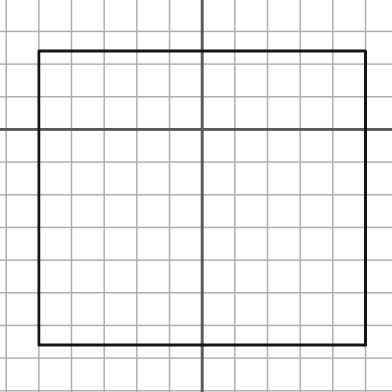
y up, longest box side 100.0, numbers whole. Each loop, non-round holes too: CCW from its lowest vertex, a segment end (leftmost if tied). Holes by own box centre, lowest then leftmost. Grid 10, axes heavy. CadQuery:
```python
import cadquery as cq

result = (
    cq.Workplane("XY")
    .moveTo(-50.0, -66.0)
    .lineTo(50.0, -66.0)
    .lineTo(50.0, 24.0)
    .lineTo(-50.0, 24.0)
    .close()
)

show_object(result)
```